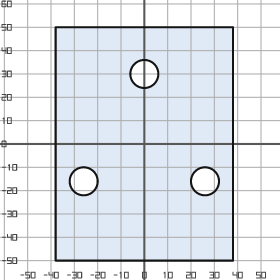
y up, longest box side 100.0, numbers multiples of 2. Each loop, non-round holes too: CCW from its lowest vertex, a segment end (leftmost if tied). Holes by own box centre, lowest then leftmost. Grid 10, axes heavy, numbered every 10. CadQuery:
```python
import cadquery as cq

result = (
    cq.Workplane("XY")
    .moveTo(-38.0, -50.0)
    .lineTo(38.0, -50.0)
    .lineTo(38.0, 50.0)
    .lineTo(-38.0, 50.0)
    .close()
    .moveTo(-26.0, -16.0)
    .circle(6.0)
    .moveTo(26.0, -16.0)
    .circle(6.0)
    .moveTo(0.0, 30.0)
    .circle(6.0)
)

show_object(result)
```